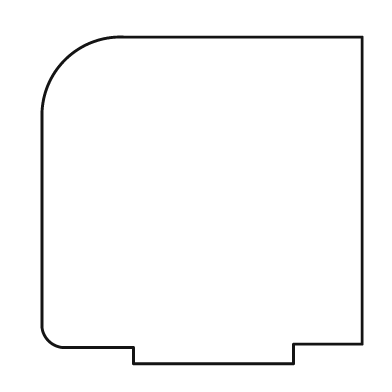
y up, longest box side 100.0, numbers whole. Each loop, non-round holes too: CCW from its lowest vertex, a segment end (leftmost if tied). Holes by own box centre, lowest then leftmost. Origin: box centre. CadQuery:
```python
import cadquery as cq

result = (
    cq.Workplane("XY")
    .moveTo(-21.0, -50.0)
    .lineTo(28.0, -50.0)
    .lineTo(28.0, -44.0)
    .lineTo(49.0, -44.0)
    .lineTo(49.0, 50.0)
    .lineTo(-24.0, 50.0)
    .threePointArc((-42.0, 43.0), (-49.0, 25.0))
    .lineTo(-49.0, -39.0)
    .threePointArc((-47.0, -43.0), (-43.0, -45.0))
    .lineTo(-21.0, -45.0)
    .close()
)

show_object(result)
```